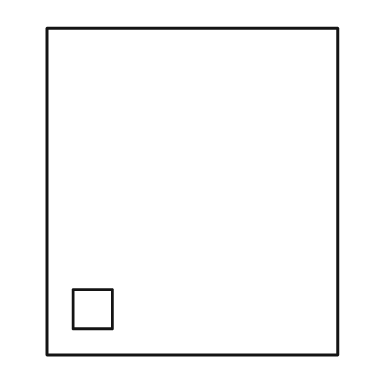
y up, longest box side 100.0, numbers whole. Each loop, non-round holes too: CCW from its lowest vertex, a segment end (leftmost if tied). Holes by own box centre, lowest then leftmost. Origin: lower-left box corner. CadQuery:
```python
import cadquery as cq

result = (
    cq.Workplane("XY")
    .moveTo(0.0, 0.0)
    .lineTo(89.0, 0.0)
    .lineTo(89.0, 100.0)
    .lineTo(0.0, 100.0)
    .close()
    .moveTo(8.0, 8.0)
    .lineTo(20.0, 8.0)
    .lineTo(20.0, 20.0)
    .lineTo(8.0, 20.0)
    .close()
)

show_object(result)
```